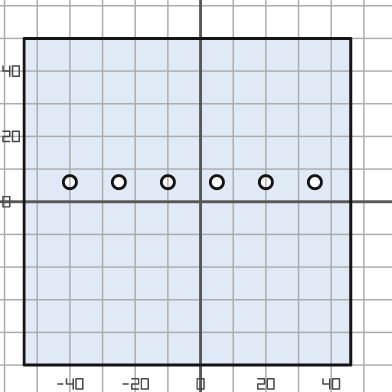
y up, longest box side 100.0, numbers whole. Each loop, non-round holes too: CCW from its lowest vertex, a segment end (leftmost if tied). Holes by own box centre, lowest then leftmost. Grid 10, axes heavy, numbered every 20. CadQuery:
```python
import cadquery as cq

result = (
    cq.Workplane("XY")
    .moveTo(-54.0, -50.0)
    .lineTo(46.0, -50.0)
    .lineTo(46.0, 50.0)
    .lineTo(-54.0, 50.0)
    .close()
    .moveTo(-40.0, 6.0)
    .circle(2.0)
    .moveTo(-25.0, 6.0)
    .circle(2.0)
    .moveTo(-10.0, 6.0)
    .circle(2.0)
    .moveTo(5.0, 6.0)
    .circle(2.0)
    .moveTo(20.0, 6.0)
    .circle(2.0)
    .moveTo(35.0, 6.0)
    .circle(2.0)
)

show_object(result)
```